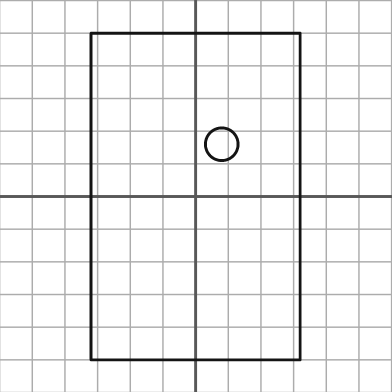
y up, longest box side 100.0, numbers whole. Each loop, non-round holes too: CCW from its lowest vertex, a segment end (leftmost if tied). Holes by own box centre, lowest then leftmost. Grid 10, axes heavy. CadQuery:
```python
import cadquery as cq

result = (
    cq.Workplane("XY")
    .moveTo(-32.0, -50.0)
    .lineTo(32.0, -50.0)
    .lineTo(32.0, 50.0)
    .lineTo(-32.0, 50.0)
    .close()
    .moveTo(8.0, 16.0)
    .circle(5.0)
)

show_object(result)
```